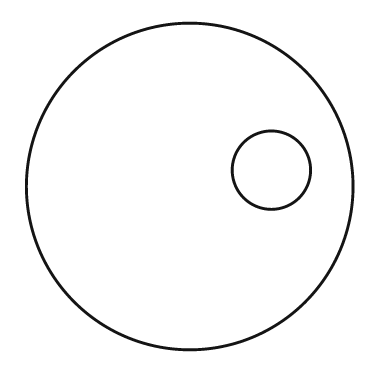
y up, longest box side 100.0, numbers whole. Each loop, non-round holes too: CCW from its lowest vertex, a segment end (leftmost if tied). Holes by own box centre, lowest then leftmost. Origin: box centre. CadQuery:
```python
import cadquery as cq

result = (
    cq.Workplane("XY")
    .moveTo(0.0, 0.0)
    .circle(50.0)
    .moveTo(25.0, 5.0)
    .circle(12.0)
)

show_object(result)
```